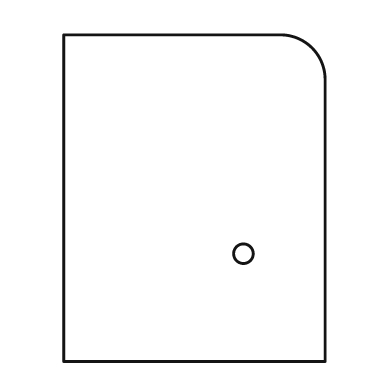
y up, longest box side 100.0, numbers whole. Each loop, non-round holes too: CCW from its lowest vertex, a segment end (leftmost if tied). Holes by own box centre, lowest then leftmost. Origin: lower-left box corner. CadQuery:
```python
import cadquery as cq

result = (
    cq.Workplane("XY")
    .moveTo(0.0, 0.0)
    .lineTo(80.0, 0.0)
    .lineTo(80.0, 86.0)
    .threePointArc((76.0, 96.0), (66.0, 100.0))
    .lineTo(0.0, 100.0)
    .close()
    .moveTo(55.0, 33.0)
    .circle(3.0)
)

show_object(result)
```